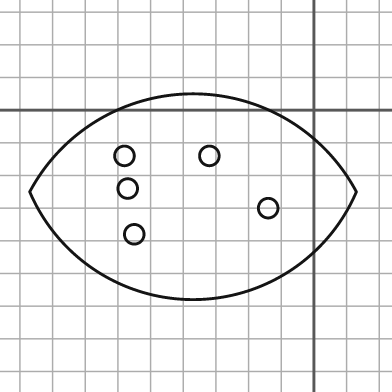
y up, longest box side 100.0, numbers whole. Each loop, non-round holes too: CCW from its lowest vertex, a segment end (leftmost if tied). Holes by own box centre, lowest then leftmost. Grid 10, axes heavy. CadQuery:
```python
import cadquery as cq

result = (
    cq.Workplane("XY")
    .moveTo(-87.0, -25.0)
    .threePointArc((-37.0, -58.0), (13.0, -25.0))
    .threePointArc((-37.0, 5.0), (-87.0, -25.0))
    .close()
    .moveTo(-55.0, -38.0)
    .circle(3.0)
    .moveTo(-14.0, -30.0)
    .circle(3.0)
    .moveTo(-57.0, -24.0)
    .circle(3.0)
    .moveTo(-58.0, -14.0)
    .circle(3.0)
    .moveTo(-32.0, -14.0)
    .circle(3.0)
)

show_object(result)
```